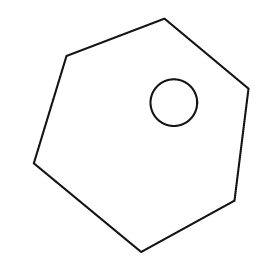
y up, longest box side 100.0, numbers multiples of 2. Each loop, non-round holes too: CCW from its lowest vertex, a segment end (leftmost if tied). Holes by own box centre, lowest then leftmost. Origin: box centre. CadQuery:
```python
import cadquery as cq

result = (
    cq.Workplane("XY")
    .moveTo(0.0, -50.0)
    .lineTo(40.0, -28.0)
    .lineTo(46.0, 20.0)
    .lineTo(10.0, 50.0)
    .lineTo(-32.0, 34.0)
    .lineTo(-46.0, -12.0)
    .close()
    .moveTo(14.0, 14.0)
    .circle(10.0)
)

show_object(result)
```